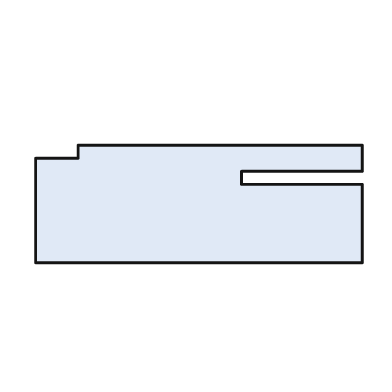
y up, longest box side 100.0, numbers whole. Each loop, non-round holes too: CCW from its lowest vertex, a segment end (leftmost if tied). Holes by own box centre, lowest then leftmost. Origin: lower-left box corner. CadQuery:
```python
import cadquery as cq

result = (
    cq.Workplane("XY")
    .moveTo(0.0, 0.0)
    .lineTo(100.0, 0.0)
    .lineTo(100.0, 24.0)
    .lineTo(63.0, 24.0)
    .lineTo(63.0, 28.0)
    .lineTo(100.0, 28.0)
    .lineTo(100.0, 36.0)
    .lineTo(13.0, 36.0)
    .lineTo(13.0, 32.0)
    .lineTo(0.0, 32.0)
    .close()
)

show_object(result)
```